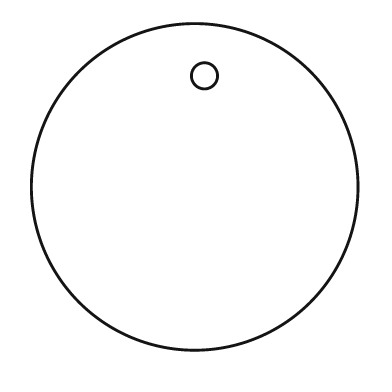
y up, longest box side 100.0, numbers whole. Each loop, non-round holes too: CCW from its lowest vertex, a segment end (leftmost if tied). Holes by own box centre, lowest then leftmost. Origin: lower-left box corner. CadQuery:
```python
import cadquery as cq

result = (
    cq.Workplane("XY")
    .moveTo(50.0, 50.0)
    .circle(50.0)
    .moveTo(53.0, 84.0)
    .circle(4.0)
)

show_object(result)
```